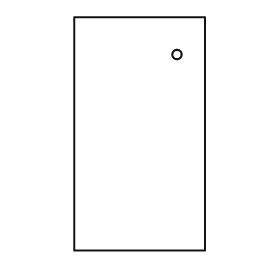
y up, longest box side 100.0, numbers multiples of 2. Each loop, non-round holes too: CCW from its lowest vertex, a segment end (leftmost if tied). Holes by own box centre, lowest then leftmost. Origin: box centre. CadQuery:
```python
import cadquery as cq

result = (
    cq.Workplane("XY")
    .moveTo(-28.0, -50.0)
    .lineTo(28.0, -50.0)
    .lineTo(28.0, 50.0)
    .lineTo(-28.0, 50.0)
    .close()
    .moveTo(16.0, 34.0)
    .circle(2.0)
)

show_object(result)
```